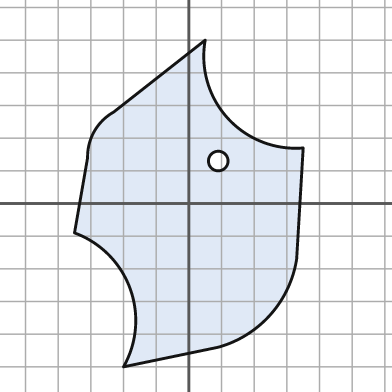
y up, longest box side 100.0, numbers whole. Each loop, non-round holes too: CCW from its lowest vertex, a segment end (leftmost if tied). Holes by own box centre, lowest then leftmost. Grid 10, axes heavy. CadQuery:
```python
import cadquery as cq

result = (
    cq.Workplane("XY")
    .moveTo(-20.0, -50.0)
    .lineTo(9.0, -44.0)
    .threePointArc((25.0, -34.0), (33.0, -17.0))
    .lineTo(35.0, 17.0)
    .threePointArc((12.0, 26.0), (5.0, 50.0))
    .lineTo(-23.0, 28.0)
    .threePointArc((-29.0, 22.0), (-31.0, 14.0))
    .lineTo(-35.0, -9.0)
    .threePointArc((-18.0, -26.0), (-20.0, -50.0))
    .close()
    .moveTo(9.0, 13.0)
    .circle(3.0)
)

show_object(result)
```